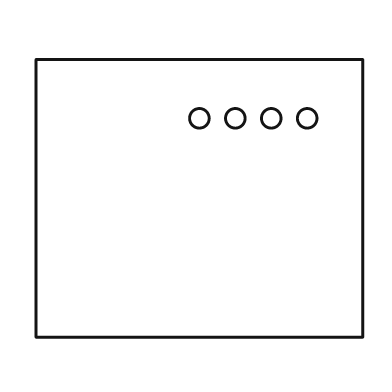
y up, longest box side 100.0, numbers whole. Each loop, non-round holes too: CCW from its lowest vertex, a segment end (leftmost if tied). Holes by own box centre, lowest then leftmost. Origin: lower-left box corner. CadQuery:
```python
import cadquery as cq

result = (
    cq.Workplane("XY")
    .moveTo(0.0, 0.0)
    .lineTo(100.0, 0.0)
    .lineTo(100.0, 85.0)
    .lineTo(0.0, 85.0)
    .close()
    .moveTo(50.0, 67.0)
    .circle(3.0)
    .moveTo(61.0, 67.0)
    .circle(3.0)
    .moveTo(72.0, 67.0)
    .circle(3.0)
    .moveTo(83.0, 67.0)
    .circle(3.0)
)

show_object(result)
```